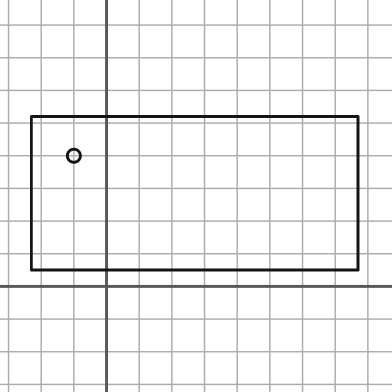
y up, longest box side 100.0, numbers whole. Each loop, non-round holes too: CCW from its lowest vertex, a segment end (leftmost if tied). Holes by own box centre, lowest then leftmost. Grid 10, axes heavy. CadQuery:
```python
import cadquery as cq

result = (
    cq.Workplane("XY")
    .moveTo(-23.0, 5.0)
    .lineTo(77.0, 5.0)
    .lineTo(77.0, 52.0)
    .lineTo(-23.0, 52.0)
    .close()
    .moveTo(-10.0, 40.0)
    .circle(2.0)
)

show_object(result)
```